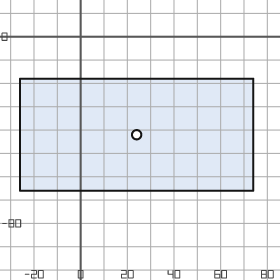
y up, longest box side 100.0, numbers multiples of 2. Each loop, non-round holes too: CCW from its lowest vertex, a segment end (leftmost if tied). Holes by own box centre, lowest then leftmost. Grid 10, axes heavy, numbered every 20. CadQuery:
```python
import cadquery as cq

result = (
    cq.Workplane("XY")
    .moveTo(-26.0, -66.0)
    .lineTo(74.0, -66.0)
    .lineTo(74.0, -18.0)
    .lineTo(-26.0, -18.0)
    .close()
    .moveTo(24.0, -42.0)
    .circle(2.0)
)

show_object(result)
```